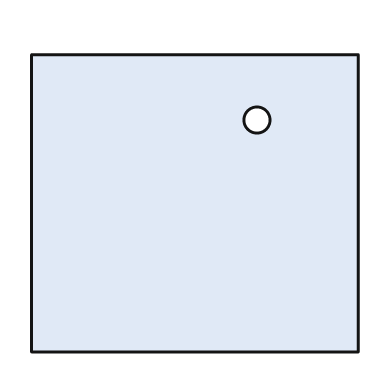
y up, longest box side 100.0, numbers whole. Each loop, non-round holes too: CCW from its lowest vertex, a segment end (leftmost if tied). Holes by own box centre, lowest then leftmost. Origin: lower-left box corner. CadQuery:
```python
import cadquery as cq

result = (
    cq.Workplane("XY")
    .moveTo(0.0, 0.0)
    .lineTo(100.0, 0.0)
    .lineTo(100.0, 91.0)
    .lineTo(0.0, 91.0)
    .close()
    .moveTo(69.0, 71.0)
    .circle(4.0)
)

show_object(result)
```